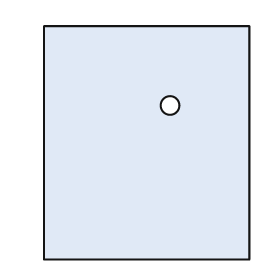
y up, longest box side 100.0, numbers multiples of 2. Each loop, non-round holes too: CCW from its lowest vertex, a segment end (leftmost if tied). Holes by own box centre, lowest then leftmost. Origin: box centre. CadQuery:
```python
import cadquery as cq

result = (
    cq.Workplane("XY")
    .moveTo(-44.0, -50.0)
    .lineTo(44.0, -50.0)
    .lineTo(44.0, 50.0)
    .lineTo(-44.0, 50.0)
    .close()
    .moveTo(10.0, 16.0)
    .circle(4.0)
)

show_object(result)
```